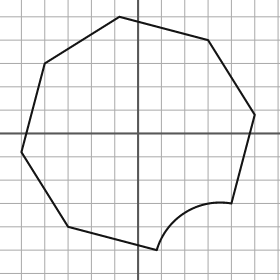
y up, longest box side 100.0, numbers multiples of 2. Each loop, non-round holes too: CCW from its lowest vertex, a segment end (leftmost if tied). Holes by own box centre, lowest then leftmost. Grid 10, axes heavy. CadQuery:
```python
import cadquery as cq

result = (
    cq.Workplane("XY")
    .moveTo(8.0, -50.0)
    .threePointArc((20.0, -34.0), (40.0, -30.0))
    .lineTo(50.0, 8.0)
    .lineTo(30.0, 40.0)
    .lineTo(-8.0, 50.0)
    .lineTo(-40.0, 30.0)
    .lineTo(-50.0, -8.0)
    .lineTo(-30.0, -40.0)
    .close()
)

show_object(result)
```